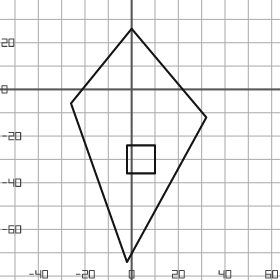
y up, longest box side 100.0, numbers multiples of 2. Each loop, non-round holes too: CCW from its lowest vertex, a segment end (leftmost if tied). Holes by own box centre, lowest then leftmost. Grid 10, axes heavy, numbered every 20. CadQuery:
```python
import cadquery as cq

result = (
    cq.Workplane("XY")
    .moveTo(-2.0, -74.0)
    .lineTo(32.0, -12.0)
    .lineTo(0.0, 26.0)
    .lineTo(-26.0, -6.0)
    .close()
    .moveTo(-2.0, -36.0)
    .lineTo(10.0, -36.0)
    .lineTo(10.0, -24.0)
    .lineTo(-2.0, -24.0)
    .close()
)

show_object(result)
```